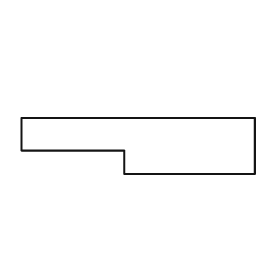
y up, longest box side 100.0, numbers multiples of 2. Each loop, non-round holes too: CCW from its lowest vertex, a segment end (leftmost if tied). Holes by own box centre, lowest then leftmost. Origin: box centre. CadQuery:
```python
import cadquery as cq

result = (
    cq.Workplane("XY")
    .moveTo(-6.0, -12.0)
    .lineTo(50.0, -12.0)
    .lineTo(50.0, 12.0)
    .lineTo(-50.0, 12.0)
    .lineTo(-50.0, -2.0)
    .lineTo(-6.0, -2.0)
    .close()
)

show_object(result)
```